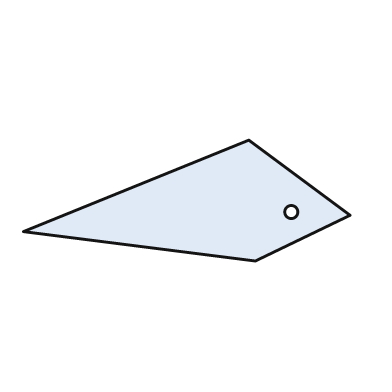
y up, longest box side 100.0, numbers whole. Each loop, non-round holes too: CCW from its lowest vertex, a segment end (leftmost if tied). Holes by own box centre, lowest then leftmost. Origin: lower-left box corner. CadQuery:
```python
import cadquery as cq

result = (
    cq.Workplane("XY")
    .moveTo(71.0, 0.0)
    .lineTo(100.0, 14.0)
    .lineTo(69.0, 37.0)
    .lineTo(0.0, 9.0)
    .close()
    .moveTo(82.0, 15.0)
    .circle(2.0)
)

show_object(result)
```